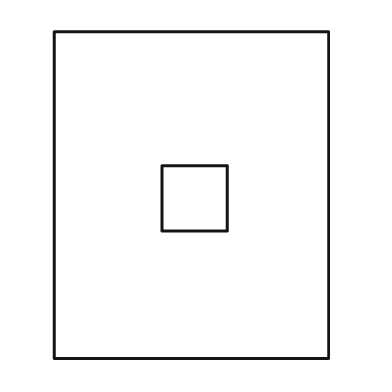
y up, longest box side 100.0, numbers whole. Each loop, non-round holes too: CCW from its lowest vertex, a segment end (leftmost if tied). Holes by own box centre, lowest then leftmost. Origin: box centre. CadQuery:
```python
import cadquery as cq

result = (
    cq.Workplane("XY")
    .moveTo(-42.0, -50.0)
    .lineTo(42.0, -50.0)
    .lineTo(42.0, 50.0)
    .lineTo(-42.0, 50.0)
    .close()
    .moveTo(-9.0, -11.0)
    .lineTo(11.0, -11.0)
    .lineTo(11.0, 9.0)
    .lineTo(-9.0, 9.0)
    .close()
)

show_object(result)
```